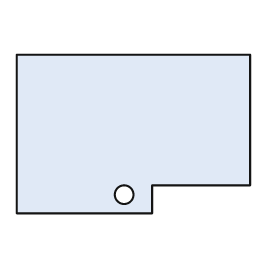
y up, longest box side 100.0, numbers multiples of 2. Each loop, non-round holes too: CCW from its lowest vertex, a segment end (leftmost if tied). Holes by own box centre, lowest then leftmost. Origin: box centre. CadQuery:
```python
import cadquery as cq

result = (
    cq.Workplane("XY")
    .moveTo(-50.0, -34.0)
    .lineTo(8.0, -34.0)
    .lineTo(8.0, -22.0)
    .lineTo(50.0, -22.0)
    .lineTo(50.0, 34.0)
    .lineTo(-50.0, 34.0)
    .close()
    .moveTo(-4.0, -26.0)
    .circle(4.0)
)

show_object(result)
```